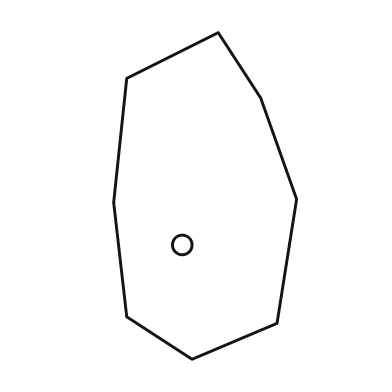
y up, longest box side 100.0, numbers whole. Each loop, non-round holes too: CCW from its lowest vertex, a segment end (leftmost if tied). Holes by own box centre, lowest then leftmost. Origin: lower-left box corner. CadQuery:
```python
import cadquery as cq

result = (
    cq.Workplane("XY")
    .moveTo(24.0, 0.0)
    .lineTo(50.0, 11.0)
    .lineTo(56.0, 49.0)
    .lineTo(45.0, 80.0)
    .lineTo(32.0, 100.0)
    .lineTo(4.0, 86.0)
    .lineTo(0.0, 48.0)
    .lineTo(4.0, 13.0)
    .close()
    .moveTo(21.0, 35.0)
    .circle(3.0)
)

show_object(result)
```